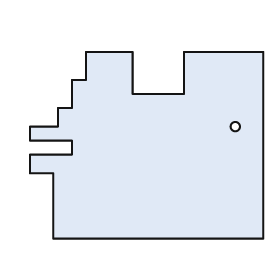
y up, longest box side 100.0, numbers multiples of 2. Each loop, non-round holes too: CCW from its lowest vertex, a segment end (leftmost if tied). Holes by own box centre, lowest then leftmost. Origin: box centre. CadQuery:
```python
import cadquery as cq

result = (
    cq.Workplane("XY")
    .moveTo(-40.0, -40.0)
    .lineTo(50.0, -40.0)
    .lineTo(50.0, 40.0)
    .lineTo(16.0, 40.0)
    .lineTo(16.0, 22.0)
    .lineTo(-6.0, 22.0)
    .lineTo(-6.0, 40.0)
    .lineTo(-26.0, 40.0)
    .lineTo(-26.0, 28.0)
    .lineTo(-32.0, 28.0)
    .lineTo(-32.0, 16.0)
    .lineTo(-38.0, 16.0)
    .lineTo(-38.0, 8.0)
    .lineTo(-50.0, 8.0)
    .lineTo(-50.0, 2.0)
    .lineTo(-32.0, 2.0)
    .lineTo(-32.0, -4.0)
    .lineTo(-50.0, -4.0)
    .lineTo(-50.0, -12.0)
    .lineTo(-40.0, -12.0)
    .close()
    .moveTo(38.0, 8.0)
    .circle(2.0)
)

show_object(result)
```